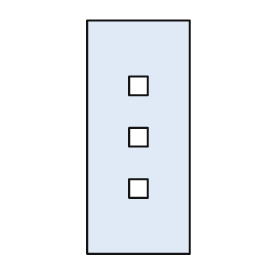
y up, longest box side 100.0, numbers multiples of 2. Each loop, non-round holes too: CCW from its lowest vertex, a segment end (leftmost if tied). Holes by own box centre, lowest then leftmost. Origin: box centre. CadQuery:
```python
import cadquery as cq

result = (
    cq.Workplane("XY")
    .moveTo(-22.0, -50.0)
    .lineTo(22.0, -50.0)
    .lineTo(22.0, 50.0)
    .lineTo(-22.0, 50.0)
    .close()
    .moveTo(-4.0, -26.0)
    .lineTo(4.0, -26.0)
    .lineTo(4.0, -18.0)
    .lineTo(-4.0, -18.0)
    .close()
    .moveTo(-4.0, -4.0)
    .lineTo(4.0, -4.0)
    .lineTo(4.0, 4.0)
    .lineTo(-4.0, 4.0)
    .close()
    .moveTo(-4.0, 18.0)
    .lineTo(4.0, 18.0)
    .lineTo(4.0, 26.0)
    .lineTo(-4.0, 26.0)
    .close()
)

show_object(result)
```